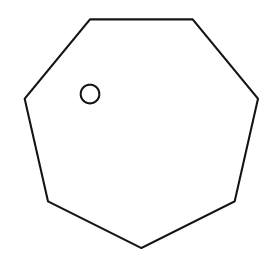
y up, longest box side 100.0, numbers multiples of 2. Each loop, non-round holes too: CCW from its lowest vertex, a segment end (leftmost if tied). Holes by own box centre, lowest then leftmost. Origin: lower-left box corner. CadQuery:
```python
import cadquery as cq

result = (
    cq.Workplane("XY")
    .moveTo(50.0, 0.0)
    .lineTo(90.0, 20.0)
    .lineTo(100.0, 64.0)
    .lineTo(72.0, 98.0)
    .lineTo(28.0, 98.0)
    .lineTo(0.0, 64.0)
    .lineTo(10.0, 20.0)
    .close()
    .moveTo(28.0, 66.0)
    .circle(4.0)
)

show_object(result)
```